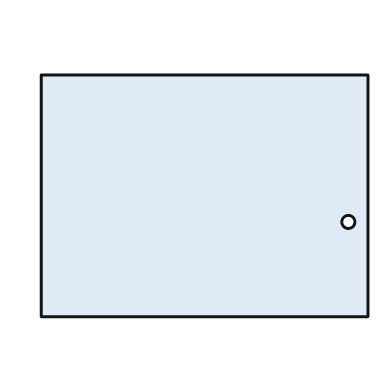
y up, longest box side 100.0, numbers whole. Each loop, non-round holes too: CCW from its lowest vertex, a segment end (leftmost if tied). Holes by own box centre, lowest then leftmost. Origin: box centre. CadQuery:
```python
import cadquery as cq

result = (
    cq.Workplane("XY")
    .moveTo(-50.0, -37.0)
    .lineTo(50.0, -37.0)
    .lineTo(50.0, 37.0)
    .lineTo(-50.0, 37.0)
    .close()
    .moveTo(44.0, -8.0)
    .circle(2.0)
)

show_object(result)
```